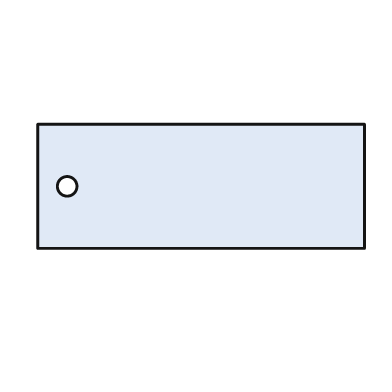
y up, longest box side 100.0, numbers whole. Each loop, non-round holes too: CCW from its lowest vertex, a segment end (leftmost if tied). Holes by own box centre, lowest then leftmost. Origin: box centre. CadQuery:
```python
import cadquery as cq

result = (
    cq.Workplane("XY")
    .moveTo(-50.0, -19.0)
    .lineTo(50.0, -19.0)
    .lineTo(50.0, 19.0)
    .lineTo(-50.0, 19.0)
    .close()
    .moveTo(-41.0, 0.0)
    .circle(3.0)
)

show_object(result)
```